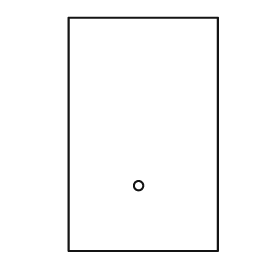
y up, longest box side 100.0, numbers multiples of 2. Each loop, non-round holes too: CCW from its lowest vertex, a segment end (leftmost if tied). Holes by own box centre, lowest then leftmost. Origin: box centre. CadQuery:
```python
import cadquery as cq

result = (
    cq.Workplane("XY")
    .moveTo(-32.0, -50.0)
    .lineTo(32.0, -50.0)
    .lineTo(32.0, 50.0)
    .lineTo(-32.0, 50.0)
    .close()
    .moveTo(-2.0, -22.0)
    .circle(2.0)
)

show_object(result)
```